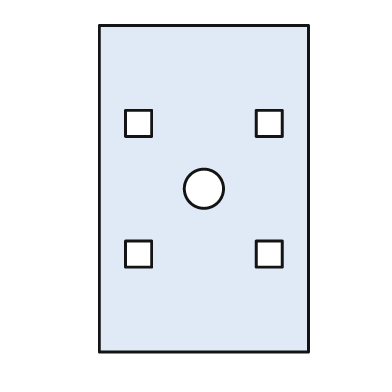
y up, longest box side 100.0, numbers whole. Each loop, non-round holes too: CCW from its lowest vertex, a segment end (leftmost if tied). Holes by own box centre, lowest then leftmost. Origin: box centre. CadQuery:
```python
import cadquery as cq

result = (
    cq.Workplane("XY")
    .moveTo(-32.0, -50.0)
    .lineTo(32.0, -50.0)
    .lineTo(32.0, 50.0)
    .lineTo(-32.0, 50.0)
    .close()
    .moveTo(-24.0, -24.0)
    .lineTo(-16.0, -24.0)
    .lineTo(-16.0, -16.0)
    .lineTo(-24.0, -16.0)
    .close()
    .moveTo(16.0, -24.0)
    .lineTo(24.0, -24.0)
    .lineTo(24.0, -16.0)
    .lineTo(16.0, -16.0)
    .close()
    .moveTo(0.0, 0.0)
    .circle(6.0)
    .moveTo(-24.0, 16.0)
    .lineTo(-16.0, 16.0)
    .lineTo(-16.0, 24.0)
    .lineTo(-24.0, 24.0)
    .close()
    .moveTo(16.0, 16.0)
    .lineTo(24.0, 16.0)
    .lineTo(24.0, 24.0)
    .lineTo(16.0, 24.0)
    .close()
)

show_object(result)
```